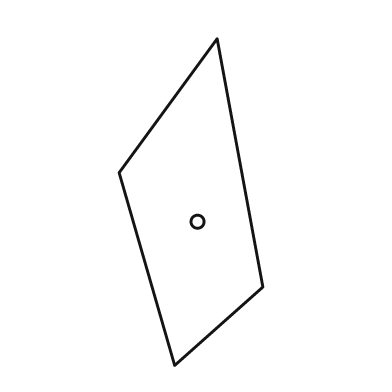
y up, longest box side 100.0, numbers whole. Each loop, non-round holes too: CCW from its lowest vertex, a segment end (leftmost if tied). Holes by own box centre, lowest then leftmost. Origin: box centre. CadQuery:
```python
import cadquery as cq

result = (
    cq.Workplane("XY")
    .moveTo(-5.0, -50.0)
    .lineTo(22.0, -26.0)
    .lineTo(8.0, 50.0)
    .lineTo(-22.0, 9.0)
    .close()
    .moveTo(2.0, -6.0)
    .circle(2.0)
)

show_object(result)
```